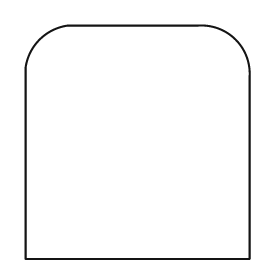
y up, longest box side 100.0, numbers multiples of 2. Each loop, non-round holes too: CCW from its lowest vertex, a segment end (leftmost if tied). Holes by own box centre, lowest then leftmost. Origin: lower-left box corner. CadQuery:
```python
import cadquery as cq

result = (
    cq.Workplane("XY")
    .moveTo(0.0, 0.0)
    .lineTo(96.0, 0.0)
    .lineTo(96.0, 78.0)
    .threePointArc((90.0, 94.0), (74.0, 100.0))
    .lineTo(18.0, 100.0)
    .threePointArc((6.0, 94.0), (0.0, 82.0))
    .close()
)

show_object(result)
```